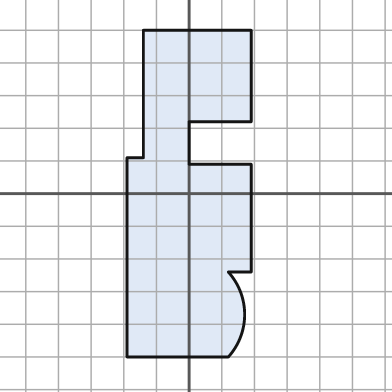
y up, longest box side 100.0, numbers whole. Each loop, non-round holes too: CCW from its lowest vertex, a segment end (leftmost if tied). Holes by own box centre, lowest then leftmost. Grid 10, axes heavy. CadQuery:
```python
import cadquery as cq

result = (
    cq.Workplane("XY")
    .moveTo(-19.0, -50.0)
    .lineTo(12.0, -50.0)
    .threePointArc((17.0, -37.0), (12.0, -24.0))
    .lineTo(19.0, -24.0)
    .lineTo(19.0, 9.0)
    .lineTo(0.0, 9.0)
    .lineTo(0.0, 22.0)
    .lineTo(19.0, 22.0)
    .lineTo(19.0, 50.0)
    .lineTo(-14.0, 50.0)
    .lineTo(-14.0, 11.0)
    .lineTo(-19.0, 11.0)
    .close()
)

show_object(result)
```